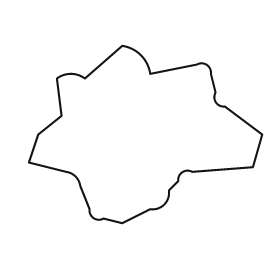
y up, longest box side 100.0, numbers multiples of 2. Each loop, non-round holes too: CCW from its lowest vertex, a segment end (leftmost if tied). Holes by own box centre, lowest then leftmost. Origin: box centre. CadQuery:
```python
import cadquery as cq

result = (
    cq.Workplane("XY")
    .moveTo(-10.0, -38.0)
    .lineTo(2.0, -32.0)
    .threePointArc((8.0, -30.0), (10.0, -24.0))
    .lineTo(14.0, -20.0)
    .threePointArc((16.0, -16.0), (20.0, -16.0))
    .lineTo(46.0, -14.0)
    .lineTo(50.0, 0.0)
    .lineTo(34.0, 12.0)
    .threePointArc((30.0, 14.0), (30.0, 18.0))
    .lineTo(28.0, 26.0)
    .threePointArc((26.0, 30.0), (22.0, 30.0))
    .lineTo(2.0, 26.0)
    .threePointArc((-2.0, 34.0), (-10.0, 38.0))
    .lineTo(-26.0, 24.0)
    .threePointArc((-32.0, 26.0), (-38.0, 24.0))
    .lineTo(-36.0, 8.0)
    .lineTo(-46.0, 0.0)
    .lineTo(-50.0, -12.0)
    .lineTo(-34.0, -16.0)
    .threePointArc((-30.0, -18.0), (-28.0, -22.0))
    .lineTo(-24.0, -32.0)
    .threePointArc((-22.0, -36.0), (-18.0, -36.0))
    .close()
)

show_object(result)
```